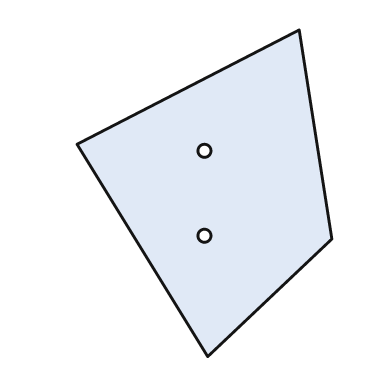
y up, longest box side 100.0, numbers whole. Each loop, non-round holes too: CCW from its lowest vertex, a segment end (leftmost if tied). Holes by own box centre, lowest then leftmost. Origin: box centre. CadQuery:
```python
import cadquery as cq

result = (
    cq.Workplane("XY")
    .moveTo(1.0, -50.0)
    .lineTo(39.0, -14.0)
    .lineTo(29.0, 50.0)
    .lineTo(-39.0, 15.0)
    .close()
    .moveTo(0.0, -13.0)
    .circle(2.0)
    .moveTo(0.0, 13.0)
    .circle(2.0)
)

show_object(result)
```